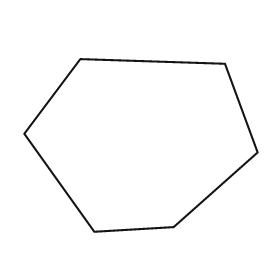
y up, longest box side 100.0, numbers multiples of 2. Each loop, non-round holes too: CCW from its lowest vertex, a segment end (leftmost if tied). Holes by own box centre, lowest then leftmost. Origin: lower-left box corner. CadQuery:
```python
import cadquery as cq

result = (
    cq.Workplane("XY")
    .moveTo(30.0, 0.0)
    .lineTo(64.0, 2.0)
    .lineTo(100.0, 34.0)
    .lineTo(86.0, 72.0)
    .lineTo(24.0, 74.0)
    .lineTo(0.0, 42.0)
    .close()
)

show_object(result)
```